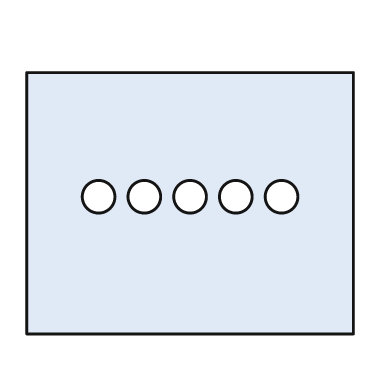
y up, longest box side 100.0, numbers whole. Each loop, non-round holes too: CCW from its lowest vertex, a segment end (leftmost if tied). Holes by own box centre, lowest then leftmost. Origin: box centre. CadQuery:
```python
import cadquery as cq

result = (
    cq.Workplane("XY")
    .moveTo(-50.0, -40.0)
    .lineTo(50.0, -40.0)
    .lineTo(50.0, 40.0)
    .lineTo(-50.0, 40.0)
    .close()
    .moveTo(-28.0, 2.0)
    .circle(5.0)
    .moveTo(-14.0, 2.0)
    .circle(5.0)
    .moveTo(0.0, 2.0)
    .circle(5.0)
    .moveTo(14.0, 2.0)
    .circle(5.0)
    .moveTo(28.0, 2.0)
    .circle(5.0)
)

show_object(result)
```